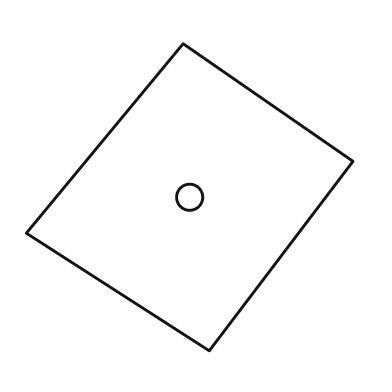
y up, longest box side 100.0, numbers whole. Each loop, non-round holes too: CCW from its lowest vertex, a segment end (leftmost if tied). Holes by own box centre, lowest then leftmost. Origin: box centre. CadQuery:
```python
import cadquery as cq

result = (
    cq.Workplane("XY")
    .moveTo(6.0, -47.0)
    .lineTo(50.0, 11.0)
    .lineTo(-2.0, 47.0)
    .lineTo(-50.0, -11.0)
    .close()
    .moveTo(0.0, 0.0)
    .circle(4.0)
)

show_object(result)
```